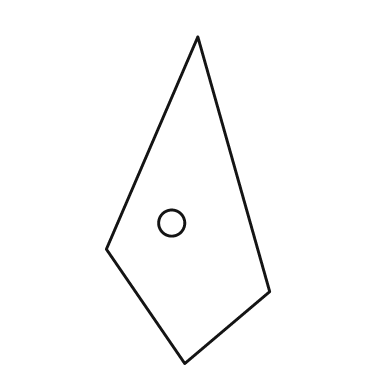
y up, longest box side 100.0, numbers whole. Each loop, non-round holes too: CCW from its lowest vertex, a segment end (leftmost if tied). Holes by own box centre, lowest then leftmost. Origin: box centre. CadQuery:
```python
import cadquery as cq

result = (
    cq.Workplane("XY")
    .moveTo(-1.0, -50.0)
    .lineTo(25.0, -28.0)
    .lineTo(3.0, 50.0)
    .lineTo(-25.0, -15.0)
    .close()
    .moveTo(-5.0, -7.0)
    .circle(4.0)
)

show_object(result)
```